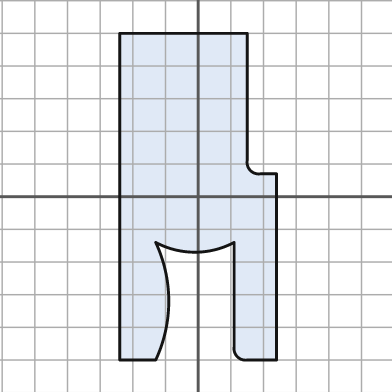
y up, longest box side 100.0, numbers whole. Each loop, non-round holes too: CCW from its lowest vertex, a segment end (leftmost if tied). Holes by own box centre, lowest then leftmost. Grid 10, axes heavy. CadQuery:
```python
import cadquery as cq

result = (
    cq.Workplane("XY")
    .moveTo(-24.0, -50.0)
    .lineTo(-13.0, -50.0)
    .threePointArc((-9.0, -32.0), (-13.0, -14.0))
    .threePointArc((-1.0, -17.0), (11.0, -14.0))
    .lineTo(11.0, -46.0)
    .threePointArc((12.0, -49.0), (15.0, -50.0))
    .lineTo(24.0, -50.0)
    .lineTo(24.0, 7.0)
    .lineTo(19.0, 7.0)
    .threePointArc((16.0, 8.0), (15.0, 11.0))
    .lineTo(15.0, 50.0)
    .lineTo(-24.0, 50.0)
    .close()
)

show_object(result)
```